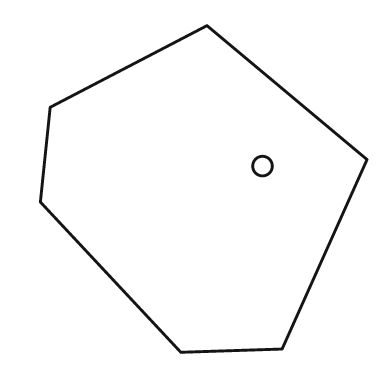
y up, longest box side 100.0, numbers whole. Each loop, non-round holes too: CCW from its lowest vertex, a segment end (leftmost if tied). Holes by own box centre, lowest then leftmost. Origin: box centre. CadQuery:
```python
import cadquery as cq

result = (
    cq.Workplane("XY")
    .moveTo(-7.0, -50.0)
    .lineTo(24.0, -49.0)
    .lineTo(50.0, 9.0)
    .lineTo(1.0, 50.0)
    .lineTo(-47.0, 25.0)
    .lineTo(-50.0, -4.0)
    .close()
    .moveTo(18.0, 7.0)
    .circle(3.0)
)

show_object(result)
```